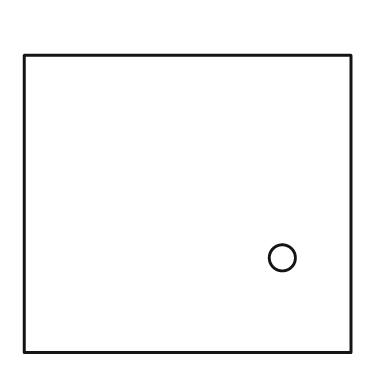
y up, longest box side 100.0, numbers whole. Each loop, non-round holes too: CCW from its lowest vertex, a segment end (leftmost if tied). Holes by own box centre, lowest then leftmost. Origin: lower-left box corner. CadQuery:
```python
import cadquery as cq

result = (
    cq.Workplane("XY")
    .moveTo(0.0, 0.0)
    .lineTo(100.0, 0.0)
    .lineTo(100.0, 91.0)
    .lineTo(0.0, 91.0)
    .close()
    .moveTo(79.0, 29.0)
    .circle(4.0)
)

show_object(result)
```